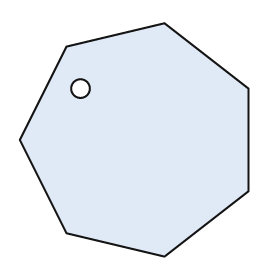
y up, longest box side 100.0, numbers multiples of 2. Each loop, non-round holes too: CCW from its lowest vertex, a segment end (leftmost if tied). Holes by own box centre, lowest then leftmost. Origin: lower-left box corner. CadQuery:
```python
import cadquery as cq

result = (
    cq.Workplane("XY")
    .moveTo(62.0, 0.0)
    .lineTo(98.0, 28.0)
    .lineTo(98.0, 72.0)
    .lineTo(62.0, 100.0)
    .lineTo(20.0, 90.0)
    .lineTo(0.0, 50.0)
    .lineTo(20.0, 10.0)
    .close()
    .moveTo(26.0, 72.0)
    .circle(4.0)
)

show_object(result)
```